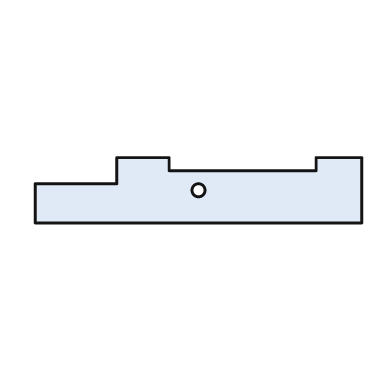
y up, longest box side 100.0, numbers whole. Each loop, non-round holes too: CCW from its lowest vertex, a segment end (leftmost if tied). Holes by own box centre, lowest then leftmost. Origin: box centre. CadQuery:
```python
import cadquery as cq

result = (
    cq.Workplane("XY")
    .moveTo(-50.0, -10.0)
    .lineTo(50.0, -10.0)
    .lineTo(50.0, 10.0)
    .lineTo(36.0, 10.0)
    .lineTo(36.0, 6.0)
    .lineTo(-9.0, 6.0)
    .lineTo(-9.0, 10.0)
    .lineTo(-25.0, 10.0)
    .lineTo(-25.0, 2.0)
    .lineTo(-50.0, 2.0)
    .close()
    .moveTo(0.0, 0.0)
    .circle(2.0)
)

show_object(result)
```